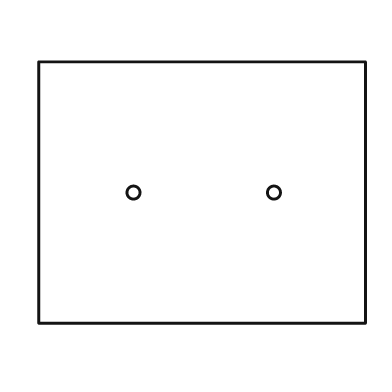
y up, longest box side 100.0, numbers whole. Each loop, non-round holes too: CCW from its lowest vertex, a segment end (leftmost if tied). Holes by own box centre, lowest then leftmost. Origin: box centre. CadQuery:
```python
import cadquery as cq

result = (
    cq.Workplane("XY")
    .moveTo(-50.0, -40.0)
    .lineTo(50.0, -40.0)
    .lineTo(50.0, 40.0)
    .lineTo(-50.0, 40.0)
    .close()
    .moveTo(-21.0, 0.0)
    .circle(2.0)
    .moveTo(22.0, 0.0)
    .circle(2.0)
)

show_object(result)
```